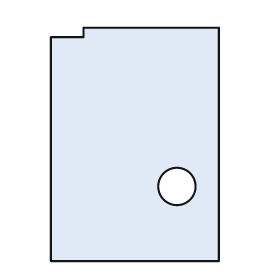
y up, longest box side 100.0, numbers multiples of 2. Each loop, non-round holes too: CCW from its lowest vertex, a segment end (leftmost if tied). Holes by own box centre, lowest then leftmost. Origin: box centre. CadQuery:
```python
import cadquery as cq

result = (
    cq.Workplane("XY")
    .moveTo(-36.0, -50.0)
    .lineTo(36.0, -50.0)
    .lineTo(36.0, 50.0)
    .lineTo(-22.0, 50.0)
    .lineTo(-22.0, 46.0)
    .lineTo(-36.0, 46.0)
    .close()
    .moveTo(18.0, -18.0)
    .circle(8.0)
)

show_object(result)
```